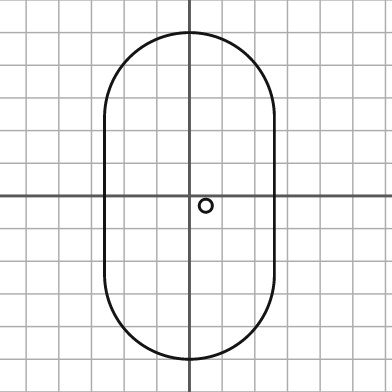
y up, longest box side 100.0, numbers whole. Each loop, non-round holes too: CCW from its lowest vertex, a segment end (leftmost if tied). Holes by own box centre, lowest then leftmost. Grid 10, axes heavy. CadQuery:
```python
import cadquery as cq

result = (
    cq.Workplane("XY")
    .moveTo(-26.0, -24.0)
    .threePointArc((0.0, -50.0), (26.0, -24.0))
    .lineTo(26.0, 24.0)
    .threePointArc((0.0, 50.0), (-26.0, 24.0))
    .close()
    .moveTo(5.0, -3.0)
    .circle(2.0)
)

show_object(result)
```